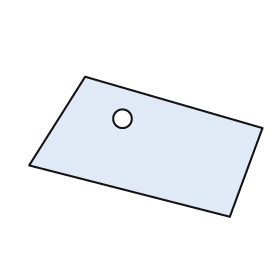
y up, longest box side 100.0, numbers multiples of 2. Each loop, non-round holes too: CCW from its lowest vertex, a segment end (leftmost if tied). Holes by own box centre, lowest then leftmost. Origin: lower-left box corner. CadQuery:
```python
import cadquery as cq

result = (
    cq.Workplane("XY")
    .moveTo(86.0, 0.0)
    .lineTo(100.0, 38.0)
    .lineTo(24.0, 60.0)
    .lineTo(0.0, 22.0)
    .close()
    .moveTo(40.0, 42.0)
    .circle(4.0)
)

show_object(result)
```